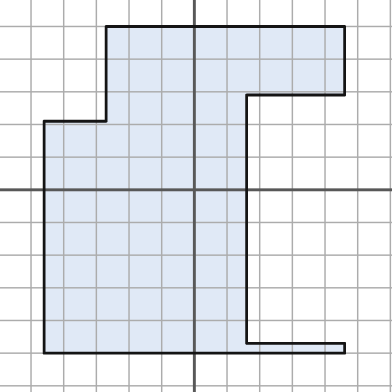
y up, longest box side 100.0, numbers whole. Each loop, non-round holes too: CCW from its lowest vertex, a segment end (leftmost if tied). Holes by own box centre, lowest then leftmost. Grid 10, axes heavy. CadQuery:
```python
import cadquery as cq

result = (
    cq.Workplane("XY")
    .moveTo(-46.0, -50.0)
    .lineTo(46.0, -50.0)
    .lineTo(46.0, -47.0)
    .lineTo(16.0, -47.0)
    .lineTo(16.0, 29.0)
    .lineTo(46.0, 29.0)
    .lineTo(46.0, 50.0)
    .lineTo(-27.0, 50.0)
    .lineTo(-27.0, 21.0)
    .lineTo(-46.0, 21.0)
    .close()
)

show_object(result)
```